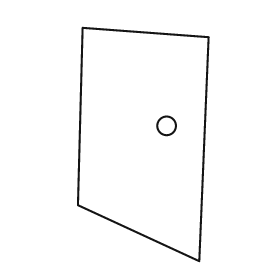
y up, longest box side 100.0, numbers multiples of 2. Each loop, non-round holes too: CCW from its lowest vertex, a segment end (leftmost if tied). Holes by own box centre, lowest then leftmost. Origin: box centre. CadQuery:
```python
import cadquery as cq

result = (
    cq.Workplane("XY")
    .moveTo(24.0, -50.0)
    .lineTo(28.0, 46.0)
    .lineTo(-26.0, 50.0)
    .lineTo(-28.0, -26.0)
    .close()
    .moveTo(10.0, 8.0)
    .circle(4.0)
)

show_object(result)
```